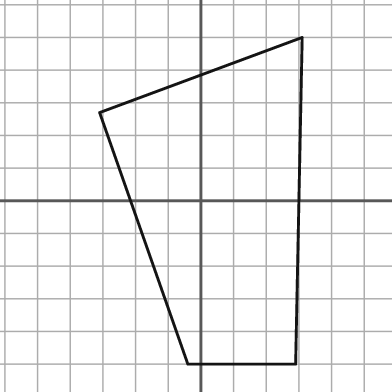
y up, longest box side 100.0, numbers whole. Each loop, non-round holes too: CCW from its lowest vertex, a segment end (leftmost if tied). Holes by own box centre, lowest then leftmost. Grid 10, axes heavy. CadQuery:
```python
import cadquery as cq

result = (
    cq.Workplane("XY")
    .moveTo(-4.0, -50.0)
    .lineTo(29.0, -50.0)
    .lineTo(31.0, 50.0)
    .lineTo(-31.0, 27.0)
    .close()
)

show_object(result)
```